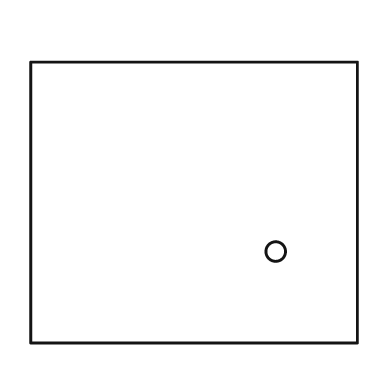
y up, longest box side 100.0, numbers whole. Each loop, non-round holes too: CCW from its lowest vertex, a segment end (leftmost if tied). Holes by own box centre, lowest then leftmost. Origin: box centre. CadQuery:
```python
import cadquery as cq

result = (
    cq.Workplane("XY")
    .moveTo(-50.0, -43.0)
    .lineTo(50.0, -43.0)
    .lineTo(50.0, 43.0)
    .lineTo(-50.0, 43.0)
    .close()
    .moveTo(25.0, -15.0)
    .circle(3.0)
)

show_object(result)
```